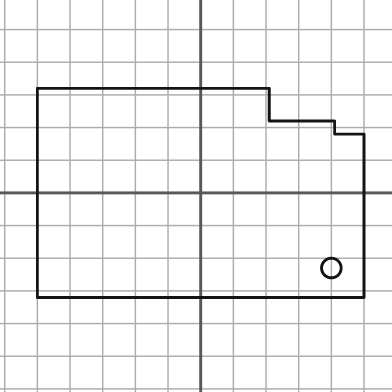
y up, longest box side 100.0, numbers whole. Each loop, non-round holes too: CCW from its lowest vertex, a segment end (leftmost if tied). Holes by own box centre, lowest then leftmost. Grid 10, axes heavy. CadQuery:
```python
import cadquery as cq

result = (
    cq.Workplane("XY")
    .moveTo(-50.0, -32.0)
    .lineTo(50.0, -32.0)
    .lineTo(50.0, 18.0)
    .lineTo(41.0, 18.0)
    .lineTo(41.0, 22.0)
    .lineTo(21.0, 22.0)
    .lineTo(21.0, 32.0)
    .lineTo(-50.0, 32.0)
    .close()
    .moveTo(40.0, -23.0)
    .circle(3.0)
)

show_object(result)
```